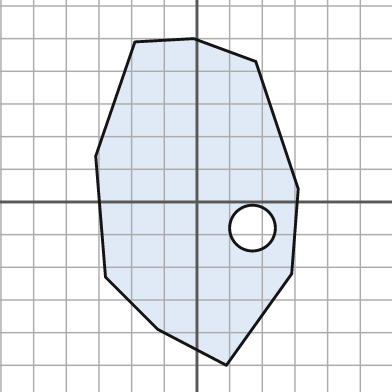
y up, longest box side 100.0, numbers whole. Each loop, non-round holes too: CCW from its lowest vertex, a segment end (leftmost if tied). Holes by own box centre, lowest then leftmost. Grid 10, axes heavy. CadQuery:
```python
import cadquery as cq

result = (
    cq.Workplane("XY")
    .moveTo(9.0, -50.0)
    .lineTo(29.0, -22.0)
    .lineTo(31.0, 4.0)
    .lineTo(18.0, 43.0)
    .lineTo(-1.0, 50.0)
    .lineTo(-19.0, 49.0)
    .lineTo(-31.0, 14.0)
    .lineTo(-28.0, -23.0)
    .lineTo(-12.0, -39.0)
    .close()
    .moveTo(17.0, -8.0)
    .circle(7.0)
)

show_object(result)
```